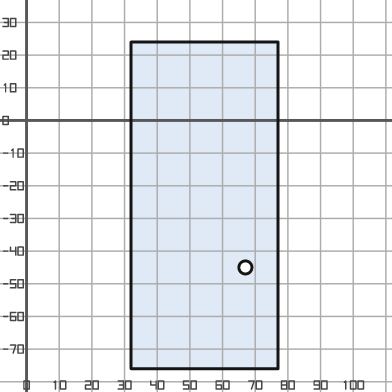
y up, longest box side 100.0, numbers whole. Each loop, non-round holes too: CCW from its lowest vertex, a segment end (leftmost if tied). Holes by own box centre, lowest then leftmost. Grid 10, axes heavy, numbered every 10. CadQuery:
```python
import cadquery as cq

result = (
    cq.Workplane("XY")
    .moveTo(32.0, -76.0)
    .lineTo(77.0, -76.0)
    .lineTo(77.0, 24.0)
    .lineTo(32.0, 24.0)
    .close()
    .moveTo(67.0, -45.0)
    .circle(2.0)
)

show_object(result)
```